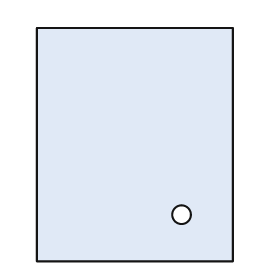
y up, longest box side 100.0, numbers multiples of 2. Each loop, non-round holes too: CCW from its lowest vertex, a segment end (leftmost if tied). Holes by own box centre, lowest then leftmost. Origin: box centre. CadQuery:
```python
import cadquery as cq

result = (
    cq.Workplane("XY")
    .moveTo(-42.0, -50.0)
    .lineTo(42.0, -50.0)
    .lineTo(42.0, 50.0)
    .lineTo(-42.0, 50.0)
    .close()
    .moveTo(20.0, -30.0)
    .circle(4.0)
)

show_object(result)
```